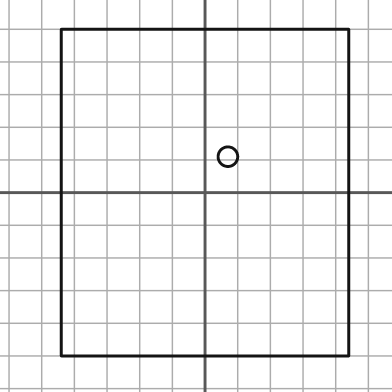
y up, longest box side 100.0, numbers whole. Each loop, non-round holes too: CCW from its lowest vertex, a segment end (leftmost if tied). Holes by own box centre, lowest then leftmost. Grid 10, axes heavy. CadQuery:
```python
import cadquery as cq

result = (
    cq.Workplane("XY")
    .moveTo(-44.0, -50.0)
    .lineTo(44.0, -50.0)
    .lineTo(44.0, 50.0)
    .lineTo(-44.0, 50.0)
    .close()
    .moveTo(7.0, 11.0)
    .circle(3.0)
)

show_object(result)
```